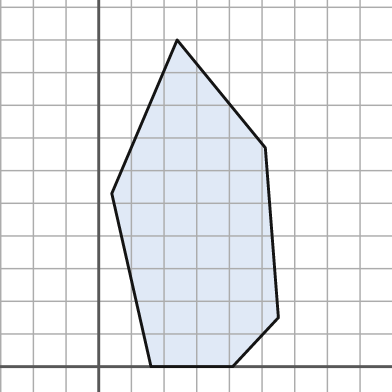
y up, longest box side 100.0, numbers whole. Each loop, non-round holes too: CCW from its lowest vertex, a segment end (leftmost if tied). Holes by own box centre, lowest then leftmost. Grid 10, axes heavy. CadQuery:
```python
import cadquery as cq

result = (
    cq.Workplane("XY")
    .moveTo(16.0, 0.0)
    .lineTo(41.0, 0.0)
    .lineTo(55.0, 15.0)
    .lineTo(51.0, 67.0)
    .lineTo(24.0, 100.0)
    .lineTo(4.0, 53.0)
    .close()
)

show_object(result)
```